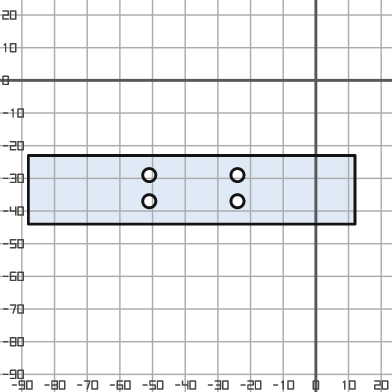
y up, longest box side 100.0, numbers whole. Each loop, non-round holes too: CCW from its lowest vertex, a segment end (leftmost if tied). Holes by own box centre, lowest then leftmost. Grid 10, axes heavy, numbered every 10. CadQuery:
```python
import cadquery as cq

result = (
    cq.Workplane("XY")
    .moveTo(-88.0, -44.0)
    .lineTo(12.0, -44.0)
    .lineTo(12.0, -23.0)
    .lineTo(-88.0, -23.0)
    .close()
    .moveTo(-51.0, -37.0)
    .circle(2.0)
    .moveTo(-24.0, -37.0)
    .circle(2.0)
    .moveTo(-51.0, -29.0)
    .circle(2.0)
    .moveTo(-24.0, -29.0)
    .circle(2.0)
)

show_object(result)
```